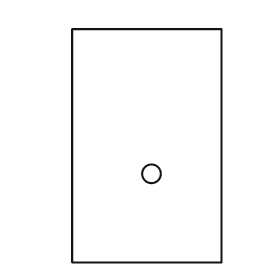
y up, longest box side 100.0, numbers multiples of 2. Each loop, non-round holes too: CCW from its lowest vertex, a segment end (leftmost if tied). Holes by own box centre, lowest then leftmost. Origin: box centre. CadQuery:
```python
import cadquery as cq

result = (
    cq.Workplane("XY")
    .moveTo(-32.0, -50.0)
    .lineTo(32.0, -50.0)
    .lineTo(32.0, 50.0)
    .lineTo(-32.0, 50.0)
    .close()
    .moveTo(2.0, -12.0)
    .circle(4.0)
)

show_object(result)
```